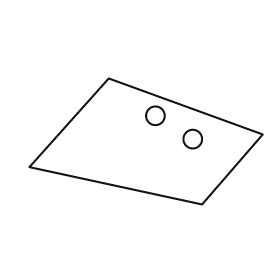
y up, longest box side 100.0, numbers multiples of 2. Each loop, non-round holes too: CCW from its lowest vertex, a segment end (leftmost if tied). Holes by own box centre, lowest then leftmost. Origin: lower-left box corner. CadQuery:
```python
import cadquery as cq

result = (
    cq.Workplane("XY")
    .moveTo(74.0, 0.0)
    .lineTo(100.0, 30.0)
    .lineTo(34.0, 54.0)
    .lineTo(0.0, 16.0)
    .close()
    .moveTo(70.0, 28.0)
    .circle(4.0)
    .moveTo(54.0, 38.0)
    .circle(4.0)
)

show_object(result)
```